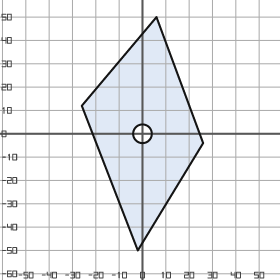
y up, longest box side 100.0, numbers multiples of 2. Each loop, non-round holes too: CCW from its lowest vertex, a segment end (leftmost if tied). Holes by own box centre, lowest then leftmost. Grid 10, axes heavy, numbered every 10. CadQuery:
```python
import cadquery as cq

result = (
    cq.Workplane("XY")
    .moveTo(-2.0, -50.0)
    .lineTo(26.0, -4.0)
    .lineTo(6.0, 50.0)
    .lineTo(-26.0, 12.0)
    .close()
    .moveTo(0.0, 0.0)
    .circle(4.0)
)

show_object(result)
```